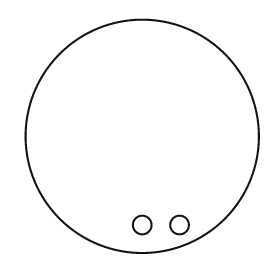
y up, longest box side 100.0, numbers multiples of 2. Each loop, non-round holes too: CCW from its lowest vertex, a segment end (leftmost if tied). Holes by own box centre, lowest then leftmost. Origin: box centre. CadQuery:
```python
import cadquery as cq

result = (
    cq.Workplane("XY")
    .moveTo(0.0, 0.0)
    .circle(50.0)
    .moveTo(0.0, -38.0)
    .circle(4.0)
    .moveTo(16.0, -38.0)
    .circle(4.0)
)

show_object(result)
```